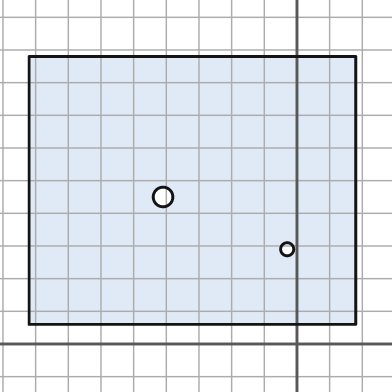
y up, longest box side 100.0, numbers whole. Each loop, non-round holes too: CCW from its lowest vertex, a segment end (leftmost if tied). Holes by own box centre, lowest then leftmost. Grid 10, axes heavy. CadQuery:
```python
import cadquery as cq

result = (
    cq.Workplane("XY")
    .moveTo(-82.0, 6.0)
    .lineTo(18.0, 6.0)
    .lineTo(18.0, 88.0)
    .lineTo(-82.0, 88.0)
    .close()
    .moveTo(-3.0, 29.0)
    .circle(2.0)
    .moveTo(-41.0, 45.0)
    .circle(3.0)
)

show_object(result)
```